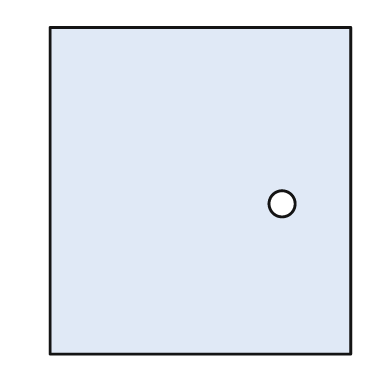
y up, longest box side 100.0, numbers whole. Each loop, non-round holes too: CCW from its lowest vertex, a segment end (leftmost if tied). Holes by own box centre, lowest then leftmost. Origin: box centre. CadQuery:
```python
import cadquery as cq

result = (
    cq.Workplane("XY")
    .moveTo(-46.0, -50.0)
    .lineTo(46.0, -50.0)
    .lineTo(46.0, 50.0)
    .lineTo(-46.0, 50.0)
    .close()
    .moveTo(25.0, -4.0)
    .circle(4.0)
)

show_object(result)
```